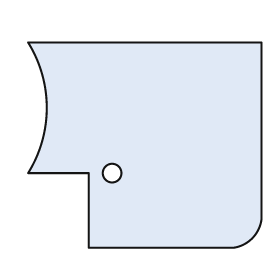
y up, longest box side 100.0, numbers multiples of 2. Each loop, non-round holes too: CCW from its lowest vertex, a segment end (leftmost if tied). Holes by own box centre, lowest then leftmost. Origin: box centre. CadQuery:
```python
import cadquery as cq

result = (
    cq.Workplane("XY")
    .moveTo(-24.0, -44.0)
    .lineTo(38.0, -44.0)
    .threePointArc((46.0, -40.0), (50.0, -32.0))
    .lineTo(50.0, 44.0)
    .lineTo(-50.0, 44.0)
    .threePointArc((-42.0, 16.0), (-50.0, -12.0))
    .lineTo(-24.0, -12.0)
    .close()
    .moveTo(-14.0, -12.0)
    .circle(4.0)
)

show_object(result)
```